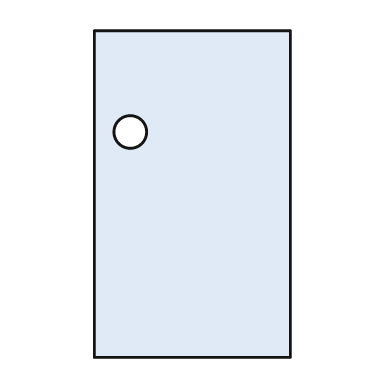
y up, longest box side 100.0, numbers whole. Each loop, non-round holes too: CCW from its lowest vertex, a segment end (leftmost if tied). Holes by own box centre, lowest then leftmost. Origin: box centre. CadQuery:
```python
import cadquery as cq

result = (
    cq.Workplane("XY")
    .moveTo(-30.0, -50.0)
    .lineTo(30.0, -50.0)
    .lineTo(30.0, 50.0)
    .lineTo(-30.0, 50.0)
    .close()
    .moveTo(-19.0, 19.0)
    .circle(5.0)
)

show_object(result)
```